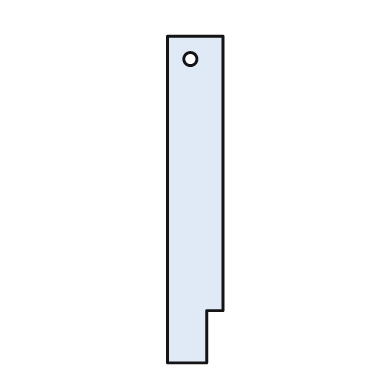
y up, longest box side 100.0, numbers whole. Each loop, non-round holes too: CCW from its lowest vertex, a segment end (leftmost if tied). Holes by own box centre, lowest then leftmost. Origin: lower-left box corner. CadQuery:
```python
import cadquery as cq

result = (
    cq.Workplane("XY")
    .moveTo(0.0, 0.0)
    .lineTo(12.0, 0.0)
    .lineTo(12.0, 16.0)
    .lineTo(17.0, 16.0)
    .lineTo(17.0, 100.0)
    .lineTo(0.0, 100.0)
    .close()
    .moveTo(7.0, 93.0)
    .circle(2.0)
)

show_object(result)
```